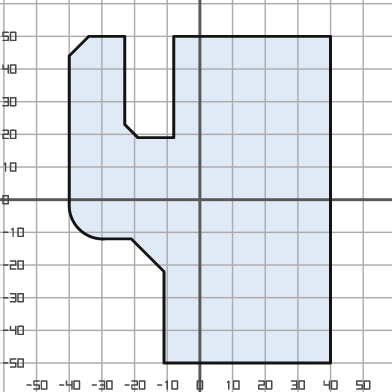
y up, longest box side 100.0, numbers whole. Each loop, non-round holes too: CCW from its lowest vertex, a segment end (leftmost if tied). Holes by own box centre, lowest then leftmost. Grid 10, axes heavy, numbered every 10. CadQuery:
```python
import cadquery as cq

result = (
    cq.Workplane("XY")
    .moveTo(-11.0, -50.0)
    .lineTo(40.0, -50.0)
    .lineTo(40.0, 50.0)
    .lineTo(-8.0, 50.0)
    .lineTo(-8.0, 19.0)
    .lineTo(-19.0, 19.0)
    .lineTo(-23.0, 23.0)
    .lineTo(-23.0, 50.0)
    .lineTo(-34.0, 50.0)
    .lineTo(-40.0, 44.0)
    .lineTo(-40.0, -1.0)
    .threePointArc((-37.0, -9.0), (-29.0, -12.0))
    .lineTo(-21.0, -12.0)
    .lineTo(-11.0, -22.0)
    .close()
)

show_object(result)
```